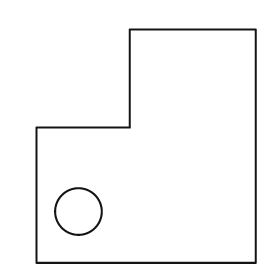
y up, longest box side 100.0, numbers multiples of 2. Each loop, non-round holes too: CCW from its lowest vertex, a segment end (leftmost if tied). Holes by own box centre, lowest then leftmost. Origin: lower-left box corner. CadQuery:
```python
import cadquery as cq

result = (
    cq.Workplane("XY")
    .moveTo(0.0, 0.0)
    .lineTo(94.0, 0.0)
    .lineTo(94.0, 100.0)
    .lineTo(40.0, 100.0)
    .lineTo(40.0, 58.0)
    .lineTo(0.0, 58.0)
    .close()
    .moveTo(18.0, 22.0)
    .circle(10.0)
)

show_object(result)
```